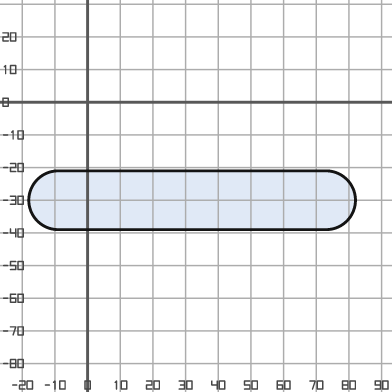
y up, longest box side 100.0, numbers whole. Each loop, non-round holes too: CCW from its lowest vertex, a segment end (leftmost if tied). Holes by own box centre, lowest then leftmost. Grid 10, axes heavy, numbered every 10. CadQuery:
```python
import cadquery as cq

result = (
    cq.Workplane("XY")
    .moveTo(-9.0, -39.0)
    .lineTo(73.0, -39.0)
    .threePointArc((82.0, -30.0), (73.0, -21.0))
    .lineTo(-9.0, -21.0)
    .threePointArc((-18.0, -30.0), (-9.0, -39.0))
    .close()
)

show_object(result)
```